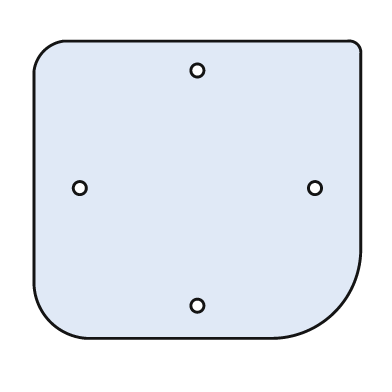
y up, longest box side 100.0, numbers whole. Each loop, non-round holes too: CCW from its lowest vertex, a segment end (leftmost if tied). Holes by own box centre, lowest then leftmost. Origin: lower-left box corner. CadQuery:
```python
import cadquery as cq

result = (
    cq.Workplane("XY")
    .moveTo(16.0, 0.0)
    .lineTo(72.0, 0.0)
    .threePointArc((92.0, 8.0), (100.0, 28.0))
    .lineTo(100.0, 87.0)
    .threePointArc((99.0, 90.0), (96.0, 91.0))
    .lineTo(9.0, 91.0)
    .threePointArc((3.0, 88.0), (0.0, 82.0))
    .lineTo(0.0, 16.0)
    .threePointArc((5.0, 5.0), (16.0, 0.0))
    .close()
    .moveTo(50.0, 10.0)
    .circle(2.0)
    .moveTo(14.0, 46.0)
    .circle(2.0)
    .moveTo(86.0, 46.0)
    .circle(2.0)
    .moveTo(50.0, 82.0)
    .circle(2.0)
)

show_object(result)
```